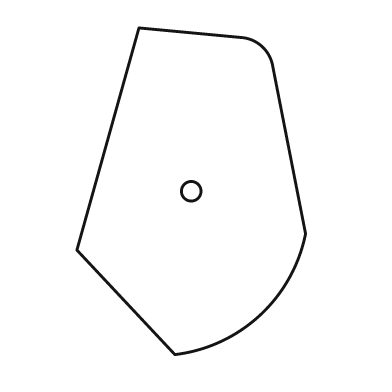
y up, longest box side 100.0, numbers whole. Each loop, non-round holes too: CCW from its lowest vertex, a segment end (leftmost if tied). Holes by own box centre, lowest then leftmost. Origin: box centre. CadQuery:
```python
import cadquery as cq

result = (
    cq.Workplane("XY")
    .moveTo(-5.0, -50.0)
    .threePointArc((21.0, -38.0), (35.0, -13.0))
    .lineTo(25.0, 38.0)
    .threePointArc((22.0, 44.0), (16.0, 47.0))
    .lineTo(-16.0, 50.0)
    .lineTo(-35.0, -18.0)
    .close()
    .moveTo(0.0, 0.0)
    .circle(3.0)
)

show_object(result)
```